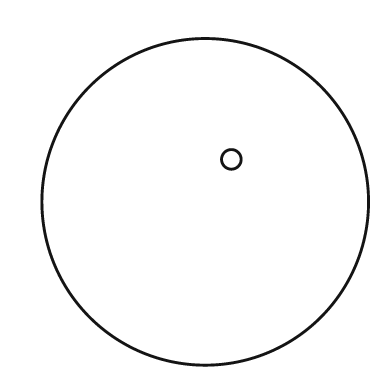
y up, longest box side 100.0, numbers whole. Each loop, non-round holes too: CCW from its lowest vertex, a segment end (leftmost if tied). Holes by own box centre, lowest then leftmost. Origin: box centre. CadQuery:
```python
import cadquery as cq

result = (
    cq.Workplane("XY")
    .moveTo(0.0, 0.0)
    .circle(50.0)
    .moveTo(8.0, 13.0)
    .circle(3.0)
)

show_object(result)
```